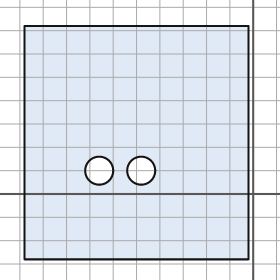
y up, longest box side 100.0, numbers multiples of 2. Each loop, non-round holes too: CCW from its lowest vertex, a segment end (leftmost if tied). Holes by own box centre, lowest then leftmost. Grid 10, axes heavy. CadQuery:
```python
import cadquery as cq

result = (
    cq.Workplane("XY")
    .moveTo(-98.0, -28.0)
    .lineTo(-2.0, -28.0)
    .lineTo(-2.0, 72.0)
    .lineTo(-98.0, 72.0)
    .close()
    .moveTo(-66.0, 10.0)
    .circle(6.0)
    .moveTo(-48.0, 10.0)
    .circle(6.0)
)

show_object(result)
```